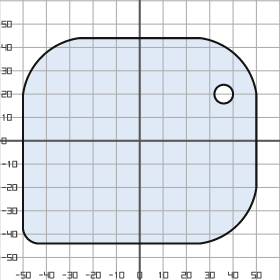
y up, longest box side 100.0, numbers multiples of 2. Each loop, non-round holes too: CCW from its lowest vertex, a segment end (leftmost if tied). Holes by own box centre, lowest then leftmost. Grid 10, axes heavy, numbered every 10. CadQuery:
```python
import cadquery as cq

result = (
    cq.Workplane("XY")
    .moveTo(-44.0, -44.0)
    .lineTo(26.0, -44.0)
    .threePointArc((42.0, -36.0), (50.0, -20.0))
    .lineTo(50.0, 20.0)
    .threePointArc((42.0, 36.0), (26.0, 44.0))
    .lineTo(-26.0, 44.0)
    .threePointArc((-42.0, 36.0), (-50.0, 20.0))
    .lineTo(-50.0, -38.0)
    .threePointArc((-48.0, -42.0), (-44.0, -44.0))
    .close()
    .moveTo(36.0, 20.0)
    .circle(4.0)
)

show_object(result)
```